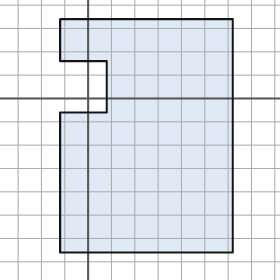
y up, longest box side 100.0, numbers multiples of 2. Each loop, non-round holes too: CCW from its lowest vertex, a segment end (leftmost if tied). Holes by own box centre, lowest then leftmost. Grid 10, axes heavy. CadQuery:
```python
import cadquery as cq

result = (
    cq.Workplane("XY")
    .moveTo(-12.0, -66.0)
    .lineTo(62.0, -66.0)
    .lineTo(62.0, 34.0)
    .lineTo(-12.0, 34.0)
    .lineTo(-12.0, 16.0)
    .lineTo(8.0, 16.0)
    .lineTo(8.0, -6.0)
    .lineTo(-12.0, -6.0)
    .close()
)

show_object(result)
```